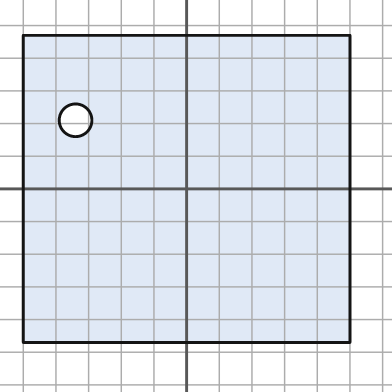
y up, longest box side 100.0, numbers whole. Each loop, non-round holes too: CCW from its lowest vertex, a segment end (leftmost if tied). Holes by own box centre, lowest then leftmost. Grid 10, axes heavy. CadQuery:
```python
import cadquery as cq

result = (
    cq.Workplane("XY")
    .moveTo(-50.0, -47.0)
    .lineTo(50.0, -47.0)
    .lineTo(50.0, 47.0)
    .lineTo(-50.0, 47.0)
    .close()
    .moveTo(-34.0, 21.0)
    .circle(5.0)
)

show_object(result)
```